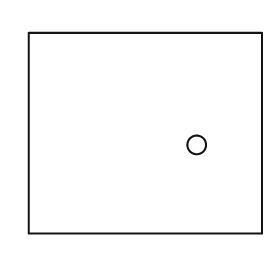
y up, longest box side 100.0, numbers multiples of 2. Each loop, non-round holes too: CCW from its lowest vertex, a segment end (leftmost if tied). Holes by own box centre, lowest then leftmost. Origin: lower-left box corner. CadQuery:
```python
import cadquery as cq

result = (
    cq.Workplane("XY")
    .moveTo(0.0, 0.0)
    .lineTo(100.0, 0.0)
    .lineTo(100.0, 86.0)
    .lineTo(0.0, 86.0)
    .close()
    .moveTo(72.0, 38.0)
    .circle(4.0)
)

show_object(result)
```